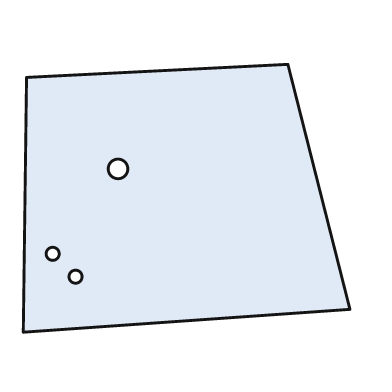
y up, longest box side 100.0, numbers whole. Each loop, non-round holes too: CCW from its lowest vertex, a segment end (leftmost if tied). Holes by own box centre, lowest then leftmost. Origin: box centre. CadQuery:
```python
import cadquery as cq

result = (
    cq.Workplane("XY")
    .moveTo(-50.0, -41.0)
    .lineTo(50.0, -34.0)
    .lineTo(31.0, 41.0)
    .lineTo(-49.0, 37.0)
    .close()
    .moveTo(-34.0, -24.0)
    .circle(2.0)
    .moveTo(-41.0, -17.0)
    .circle(2.0)
    .moveTo(-21.0, 9.0)
    .circle(3.0)
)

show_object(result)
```